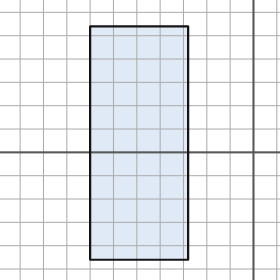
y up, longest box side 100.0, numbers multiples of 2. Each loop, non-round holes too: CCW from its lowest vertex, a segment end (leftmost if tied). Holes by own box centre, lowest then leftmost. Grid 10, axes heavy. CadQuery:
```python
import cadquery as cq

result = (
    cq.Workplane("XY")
    .moveTo(-70.0, -46.0)
    .lineTo(-28.0, -46.0)
    .lineTo(-28.0, 54.0)
    .lineTo(-70.0, 54.0)
    .close()
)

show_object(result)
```